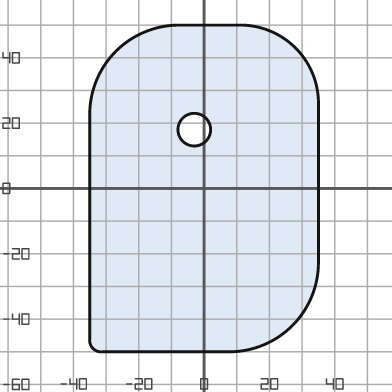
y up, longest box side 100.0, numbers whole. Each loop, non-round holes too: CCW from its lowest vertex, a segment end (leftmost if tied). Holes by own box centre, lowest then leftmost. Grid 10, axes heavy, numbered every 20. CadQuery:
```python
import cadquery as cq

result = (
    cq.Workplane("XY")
    .moveTo(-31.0, -50.0)
    .lineTo(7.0, -50.0)
    .threePointArc((27.0, -42.0), (35.0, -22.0))
    .lineTo(35.0, 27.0)
    .threePointArc((28.0, 43.0), (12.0, 50.0))
    .lineTo(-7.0, 50.0)
    .threePointArc((-27.0, 42.0), (-35.0, 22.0))
    .lineTo(-35.0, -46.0)
    .threePointArc((-34.0, -49.0), (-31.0, -50.0))
    .close()
    .moveTo(-3.0, 18.0)
    .circle(5.0)
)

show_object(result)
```